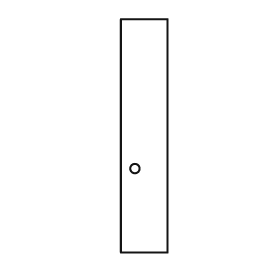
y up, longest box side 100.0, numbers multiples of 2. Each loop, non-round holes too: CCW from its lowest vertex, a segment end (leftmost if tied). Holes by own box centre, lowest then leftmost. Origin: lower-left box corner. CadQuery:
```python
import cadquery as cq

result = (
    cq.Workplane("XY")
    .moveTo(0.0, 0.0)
    .lineTo(20.0, 0.0)
    .lineTo(20.0, 100.0)
    .lineTo(0.0, 100.0)
    .close()
    .moveTo(6.0, 36.0)
    .circle(2.0)
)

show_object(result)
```